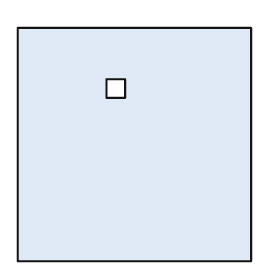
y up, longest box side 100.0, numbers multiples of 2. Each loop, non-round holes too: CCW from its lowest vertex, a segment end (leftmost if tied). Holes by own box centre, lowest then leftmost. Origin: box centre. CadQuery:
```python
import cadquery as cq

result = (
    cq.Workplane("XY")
    .moveTo(-50.0, -50.0)
    .lineTo(50.0, -50.0)
    .lineTo(50.0, 50.0)
    .lineTo(-50.0, 50.0)
    .close()
    .moveTo(-12.0, 20.0)
    .lineTo(-4.0, 20.0)
    .lineTo(-4.0, 28.0)
    .lineTo(-12.0, 28.0)
    .close()
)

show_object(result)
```